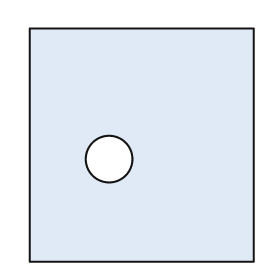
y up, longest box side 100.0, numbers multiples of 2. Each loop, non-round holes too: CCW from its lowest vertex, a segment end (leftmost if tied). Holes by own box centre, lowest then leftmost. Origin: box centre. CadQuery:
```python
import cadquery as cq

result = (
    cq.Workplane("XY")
    .moveTo(-48.0, -50.0)
    .lineTo(48.0, -50.0)
    .lineTo(48.0, 50.0)
    .lineTo(-48.0, 50.0)
    .close()
    .moveTo(-14.0, -6.0)
    .circle(10.0)
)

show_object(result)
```